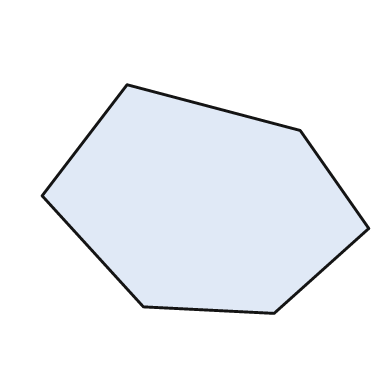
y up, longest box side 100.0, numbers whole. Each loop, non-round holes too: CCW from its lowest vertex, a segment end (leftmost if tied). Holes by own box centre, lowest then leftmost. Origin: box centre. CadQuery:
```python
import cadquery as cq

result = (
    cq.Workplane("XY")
    .moveTo(21.0, -35.0)
    .lineTo(50.0, -9.0)
    .lineTo(29.0, 21.0)
    .lineTo(-24.0, 35.0)
    .lineTo(-50.0, 1.0)
    .lineTo(-19.0, -33.0)
    .close()
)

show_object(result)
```